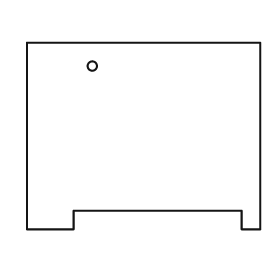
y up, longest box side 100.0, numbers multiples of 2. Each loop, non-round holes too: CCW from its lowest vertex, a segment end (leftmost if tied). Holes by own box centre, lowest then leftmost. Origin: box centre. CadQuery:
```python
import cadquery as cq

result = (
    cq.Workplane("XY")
    .moveTo(-50.0, -40.0)
    .lineTo(-30.0, -40.0)
    .lineTo(-30.0, -32.0)
    .lineTo(42.0, -32.0)
    .lineTo(42.0, -40.0)
    .lineTo(50.0, -40.0)
    .lineTo(50.0, 40.0)
    .lineTo(-50.0, 40.0)
    .close()
    .moveTo(-22.0, 30.0)
    .circle(2.0)
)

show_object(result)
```